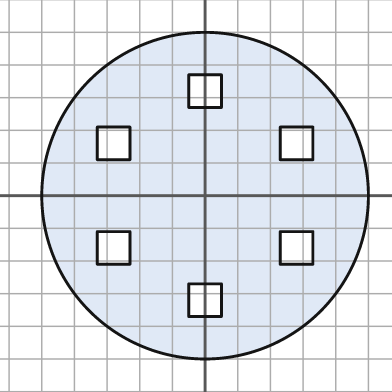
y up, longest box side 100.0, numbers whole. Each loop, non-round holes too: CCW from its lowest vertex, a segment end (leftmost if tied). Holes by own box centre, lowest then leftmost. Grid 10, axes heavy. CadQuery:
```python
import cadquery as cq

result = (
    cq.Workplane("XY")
    .moveTo(0.0, 0.0)
    .circle(50.0)
    .moveTo(-5.0, -37.0)
    .lineTo(5.0, -37.0)
    .lineTo(5.0, -27.0)
    .lineTo(-5.0, -27.0)
    .close()
    .moveTo(-33.0, -21.0)
    .lineTo(-23.0, -21.0)
    .lineTo(-23.0, -11.0)
    .lineTo(-33.0, -11.0)
    .close()
    .moveTo(23.0, -21.0)
    .lineTo(33.0, -21.0)
    .lineTo(33.0, -11.0)
    .lineTo(23.0, -11.0)
    .close()
    .moveTo(-33.0, 11.0)
    .lineTo(-23.0, 11.0)
    .lineTo(-23.0, 21.0)
    .lineTo(-33.0, 21.0)
    .close()
    .moveTo(23.0, 11.0)
    .lineTo(33.0, 11.0)
    .lineTo(33.0, 21.0)
    .lineTo(23.0, 21.0)
    .close()
    .moveTo(-5.0, 27.0)
    .lineTo(5.0, 27.0)
    .lineTo(5.0, 37.0)
    .lineTo(-5.0, 37.0)
    .close()
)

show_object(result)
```